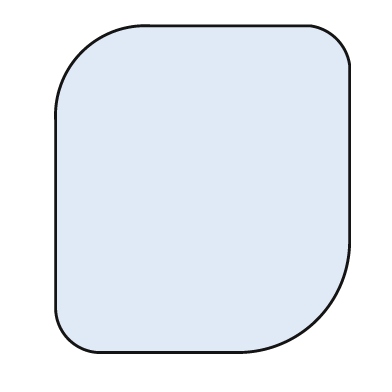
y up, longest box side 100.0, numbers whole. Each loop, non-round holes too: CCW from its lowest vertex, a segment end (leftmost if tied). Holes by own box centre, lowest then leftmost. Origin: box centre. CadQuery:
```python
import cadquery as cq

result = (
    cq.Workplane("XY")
    .moveTo(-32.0, -50.0)
    .lineTo(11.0, -50.0)
    .threePointArc((35.0, -40.0), (45.0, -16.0))
    .lineTo(45.0, 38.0)
    .threePointArc((41.0, 46.0), (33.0, 50.0))
    .lineTo(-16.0, 50.0)
    .threePointArc((-37.0, 42.0), (-45.0, 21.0))
    .lineTo(-45.0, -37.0)
    .threePointArc((-41.0, -46.0), (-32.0, -50.0))
    .close()
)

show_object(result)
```